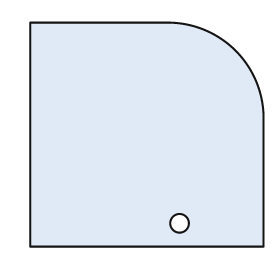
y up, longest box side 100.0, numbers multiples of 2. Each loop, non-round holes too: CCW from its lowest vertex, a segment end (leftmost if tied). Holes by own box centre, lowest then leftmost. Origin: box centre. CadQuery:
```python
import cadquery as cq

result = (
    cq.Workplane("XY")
    .moveTo(-50.0, -48.0)
    .lineTo(50.0, -48.0)
    .lineTo(50.0, 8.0)
    .threePointArc((38.0, 36.0), (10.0, 48.0))
    .lineTo(-50.0, 48.0)
    .close()
    .moveTo(14.0, -38.0)
    .circle(4.0)
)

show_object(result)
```